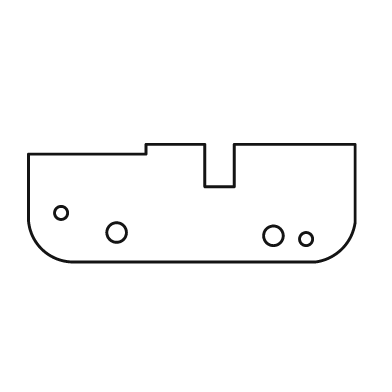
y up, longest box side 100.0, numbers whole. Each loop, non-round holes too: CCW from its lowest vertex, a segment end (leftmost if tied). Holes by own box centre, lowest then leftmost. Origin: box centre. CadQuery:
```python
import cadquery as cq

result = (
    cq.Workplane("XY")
    .moveTo(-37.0, -18.0)
    .lineTo(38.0, -18.0)
    .threePointArc((46.0, -14.0), (50.0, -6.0))
    .lineTo(50.0, 18.0)
    .lineTo(13.0, 18.0)
    .lineTo(13.0, 5.0)
    .lineTo(4.0, 5.0)
    .lineTo(4.0, 18.0)
    .lineTo(-14.0, 18.0)
    .lineTo(-14.0, 15.0)
    .lineTo(-50.0, 15.0)
    .lineTo(-50.0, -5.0)
    .threePointArc((-46.0, -14.0), (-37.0, -18.0))
    .close()
    .moveTo(35.0, -11.0)
    .circle(2.0)
    .moveTo(25.0, -10.0)
    .circle(3.0)
    .moveTo(-23.0, -9.0)
    .circle(3.0)
    .moveTo(-40.0, -3.0)
    .circle(2.0)
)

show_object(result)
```